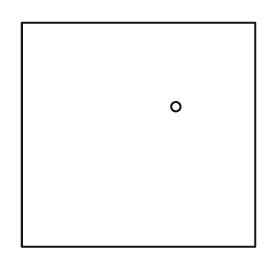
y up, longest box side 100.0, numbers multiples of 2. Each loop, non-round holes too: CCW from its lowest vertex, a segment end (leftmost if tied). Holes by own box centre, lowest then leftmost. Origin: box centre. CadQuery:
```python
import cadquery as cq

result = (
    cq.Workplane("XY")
    .moveTo(-50.0, -48.0)
    .lineTo(50.0, -48.0)
    .lineTo(50.0, 48.0)
    .lineTo(-50.0, 48.0)
    .close()
    .moveTo(16.0, 12.0)
    .circle(2.0)
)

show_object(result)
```